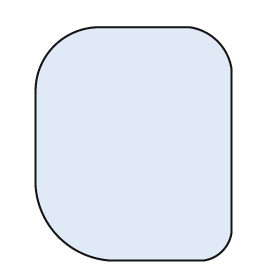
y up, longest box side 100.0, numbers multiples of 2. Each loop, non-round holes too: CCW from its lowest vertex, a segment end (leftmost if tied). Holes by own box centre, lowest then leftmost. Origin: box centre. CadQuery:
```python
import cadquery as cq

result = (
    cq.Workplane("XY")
    .moveTo(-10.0, -50.0)
    .lineTo(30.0, -50.0)
    .threePointArc((38.0, -46.0), (42.0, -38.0))
    .lineTo(42.0, 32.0)
    .threePointArc((36.0, 44.0), (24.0, 50.0))
    .lineTo(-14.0, 50.0)
    .threePointArc((-34.0, 42.0), (-42.0, 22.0))
    .lineTo(-42.0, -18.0)
    .threePointArc((-32.0, -40.0), (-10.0, -50.0))
    .close()
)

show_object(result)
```